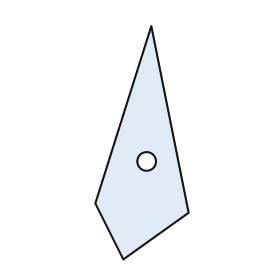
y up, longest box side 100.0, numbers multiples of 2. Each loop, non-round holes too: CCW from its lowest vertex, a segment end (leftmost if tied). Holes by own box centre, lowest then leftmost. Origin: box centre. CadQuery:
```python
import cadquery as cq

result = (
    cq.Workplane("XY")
    .moveTo(-8.0, -50.0)
    .lineTo(20.0, -30.0)
    .lineTo(4.0, 50.0)
    .lineTo(-20.0, -26.0)
    .close()
    .moveTo(2.0, -8.0)
    .circle(4.0)
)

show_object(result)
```